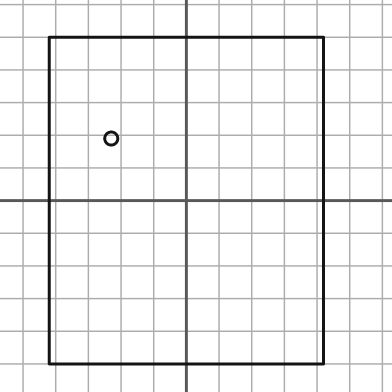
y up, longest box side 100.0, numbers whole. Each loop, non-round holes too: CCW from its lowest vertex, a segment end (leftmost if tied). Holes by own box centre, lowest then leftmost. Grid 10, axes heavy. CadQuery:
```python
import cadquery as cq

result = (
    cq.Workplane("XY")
    .moveTo(-42.0, -50.0)
    .lineTo(42.0, -50.0)
    .lineTo(42.0, 50.0)
    .lineTo(-42.0, 50.0)
    .close()
    .moveTo(-23.0, 19.0)
    .circle(2.0)
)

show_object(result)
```